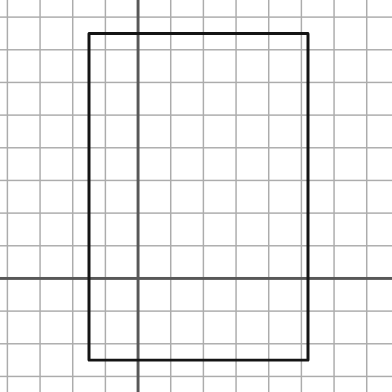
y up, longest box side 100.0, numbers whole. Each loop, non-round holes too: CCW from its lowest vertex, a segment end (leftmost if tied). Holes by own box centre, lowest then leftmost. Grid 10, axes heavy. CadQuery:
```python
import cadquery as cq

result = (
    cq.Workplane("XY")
    .moveTo(-15.0, -25.0)
    .lineTo(52.0, -25.0)
    .lineTo(52.0, 75.0)
    .lineTo(-15.0, 75.0)
    .close()
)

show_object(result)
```